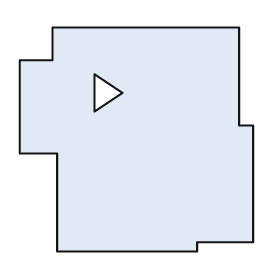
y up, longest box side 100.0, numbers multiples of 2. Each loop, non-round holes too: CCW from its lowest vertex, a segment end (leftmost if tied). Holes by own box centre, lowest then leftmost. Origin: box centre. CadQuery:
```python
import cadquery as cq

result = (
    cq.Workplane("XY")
    .moveTo(-34.0, -48.0)
    .lineTo(26.0, -48.0)
    .lineTo(26.0, -44.0)
    .lineTo(50.0, -44.0)
    .lineTo(50.0, 6.0)
    .lineTo(44.0, 6.0)
    .lineTo(44.0, 48.0)
    .lineTo(-36.0, 48.0)
    .lineTo(-36.0, 34.0)
    .lineTo(-50.0, 34.0)
    .lineTo(-50.0, -6.0)
    .lineTo(-34.0, -6.0)
    .close()
    .moveTo(-18.0, 12.0)
    .lineTo(-6.0, 20.0)
    .lineTo(-18.0, 28.0)
    .close()
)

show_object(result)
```